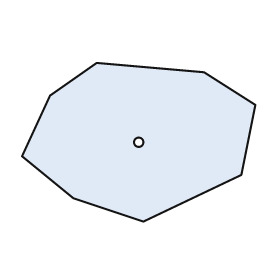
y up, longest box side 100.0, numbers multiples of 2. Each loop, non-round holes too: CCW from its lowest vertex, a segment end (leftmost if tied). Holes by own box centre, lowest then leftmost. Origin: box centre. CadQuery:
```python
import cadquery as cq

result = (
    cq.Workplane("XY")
    .moveTo(2.0, -34.0)
    .lineTo(44.0, -14.0)
    .lineTo(50.0, 16.0)
    .lineTo(28.0, 30.0)
    .lineTo(-18.0, 34.0)
    .lineTo(-38.0, 20.0)
    .lineTo(-50.0, -6.0)
    .lineTo(-28.0, -24.0)
    .close()
    .moveTo(0.0, 0.0)
    .circle(2.0)
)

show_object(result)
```